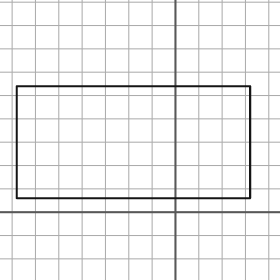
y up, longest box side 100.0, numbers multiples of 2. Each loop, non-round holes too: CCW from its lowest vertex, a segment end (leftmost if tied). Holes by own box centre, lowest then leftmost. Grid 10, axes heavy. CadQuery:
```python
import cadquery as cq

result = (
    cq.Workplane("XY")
    .moveTo(-68.0, 6.0)
    .lineTo(32.0, 6.0)
    .lineTo(32.0, 54.0)
    .lineTo(-68.0, 54.0)
    .close()
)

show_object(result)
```